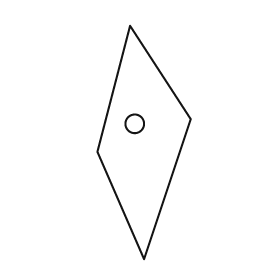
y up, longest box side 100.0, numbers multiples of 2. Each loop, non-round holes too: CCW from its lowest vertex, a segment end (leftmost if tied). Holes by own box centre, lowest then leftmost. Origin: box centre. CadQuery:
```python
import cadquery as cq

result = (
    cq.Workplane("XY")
    .moveTo(0.0, -50.0)
    .lineTo(20.0, 10.0)
    .lineTo(-6.0, 50.0)
    .lineTo(-20.0, -4.0)
    .close()
    .moveTo(-4.0, 8.0)
    .circle(4.0)
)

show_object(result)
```